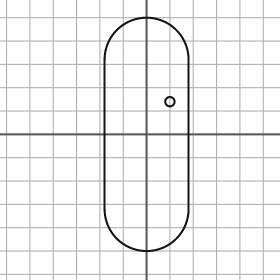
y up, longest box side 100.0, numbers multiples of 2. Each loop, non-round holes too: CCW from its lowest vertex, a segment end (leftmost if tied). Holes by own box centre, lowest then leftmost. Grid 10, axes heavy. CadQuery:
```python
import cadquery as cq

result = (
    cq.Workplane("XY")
    .moveTo(-18.0, -32.0)
    .threePointArc((0.0, -50.0), (18.0, -32.0))
    .lineTo(18.0, 32.0)
    .threePointArc((0.0, 50.0), (-18.0, 32.0))
    .close()
    .moveTo(10.0, 14.0)
    .circle(2.0)
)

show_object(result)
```